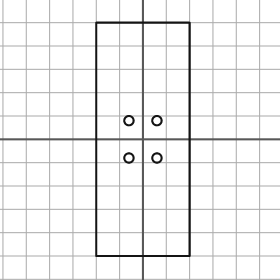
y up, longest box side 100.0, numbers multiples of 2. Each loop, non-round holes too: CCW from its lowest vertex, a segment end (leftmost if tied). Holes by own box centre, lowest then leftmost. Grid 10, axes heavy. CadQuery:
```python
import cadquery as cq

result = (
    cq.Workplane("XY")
    .moveTo(-20.0, -50.0)
    .lineTo(20.0, -50.0)
    .lineTo(20.0, 50.0)
    .lineTo(-20.0, 50.0)
    .close()
    .moveTo(-6.0, -8.0)
    .circle(2.0)
    .moveTo(6.0, -8.0)
    .circle(2.0)
    .moveTo(-6.0, 8.0)
    .circle(2.0)
    .moveTo(6.0, 8.0)
    .circle(2.0)
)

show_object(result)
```